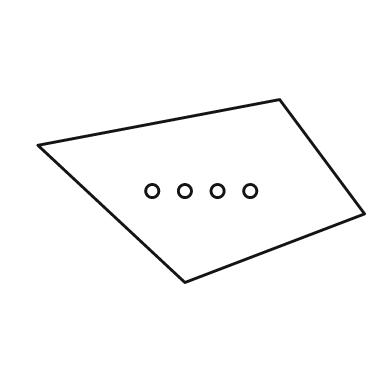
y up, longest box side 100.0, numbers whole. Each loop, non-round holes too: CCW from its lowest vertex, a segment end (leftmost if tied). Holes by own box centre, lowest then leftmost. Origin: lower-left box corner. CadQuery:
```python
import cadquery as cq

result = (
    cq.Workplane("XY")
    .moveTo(45.0, 0.0)
    .lineTo(100.0, 21.0)
    .lineTo(74.0, 56.0)
    .lineTo(0.0, 42.0)
    .close()
    .moveTo(35.0, 28.0)
    .circle(2.0)
    .moveTo(45.0, 28.0)
    .circle(2.0)
    .moveTo(55.0, 28.0)
    .circle(2.0)
    .moveTo(65.0, 28.0)
    .circle(2.0)
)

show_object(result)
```